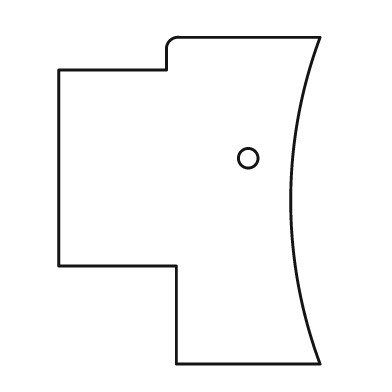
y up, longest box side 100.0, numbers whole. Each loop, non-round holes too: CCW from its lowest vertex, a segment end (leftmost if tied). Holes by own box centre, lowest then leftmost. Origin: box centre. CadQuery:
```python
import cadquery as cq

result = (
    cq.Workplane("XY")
    .moveTo(-4.0, -50.0)
    .lineTo(40.0, -50.0)
    .threePointArc((31.0, 0.0), (40.0, 50.0))
    .lineTo(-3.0, 50.0)
    .threePointArc((-6.0, 49.0), (-7.0, 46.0))
    .lineTo(-7.0, 40.0)
    .lineTo(-40.0, 40.0)
    .lineTo(-40.0, -20.0)
    .lineTo(-4.0, -20.0)
    .close()
    .moveTo(18.0, 13.0)
    .circle(3.0)
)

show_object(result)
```